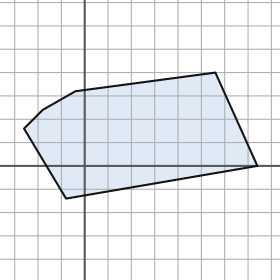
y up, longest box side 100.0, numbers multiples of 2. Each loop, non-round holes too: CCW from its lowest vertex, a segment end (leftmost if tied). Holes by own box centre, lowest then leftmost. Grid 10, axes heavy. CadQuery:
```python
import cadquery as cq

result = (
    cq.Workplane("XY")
    .moveTo(-8.0, -14.0)
    .lineTo(74.0, 0.0)
    .lineTo(56.0, 40.0)
    .lineTo(-4.0, 32.0)
    .lineTo(-18.0, 24.0)
    .lineTo(-26.0, 16.0)
    .close()
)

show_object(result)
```